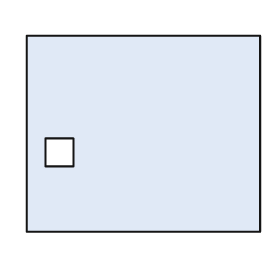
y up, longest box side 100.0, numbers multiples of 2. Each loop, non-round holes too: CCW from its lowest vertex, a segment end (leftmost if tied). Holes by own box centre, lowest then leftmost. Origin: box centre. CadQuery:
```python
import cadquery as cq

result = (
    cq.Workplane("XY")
    .moveTo(-50.0, -42.0)
    .lineTo(50.0, -42.0)
    .lineTo(50.0, 42.0)
    .lineTo(-50.0, 42.0)
    .close()
    .moveTo(-42.0, -14.0)
    .lineTo(-30.0, -14.0)
    .lineTo(-30.0, -2.0)
    .lineTo(-42.0, -2.0)
    .close()
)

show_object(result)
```